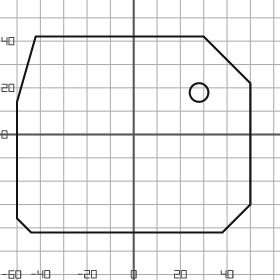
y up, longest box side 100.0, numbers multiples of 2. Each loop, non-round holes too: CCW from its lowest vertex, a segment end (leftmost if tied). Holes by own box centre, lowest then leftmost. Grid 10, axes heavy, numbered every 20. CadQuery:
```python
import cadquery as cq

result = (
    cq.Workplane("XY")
    .moveTo(-44.0, -42.0)
    .lineTo(38.0, -42.0)
    .lineTo(50.0, -30.0)
    .lineTo(50.0, 22.0)
    .lineTo(30.0, 42.0)
    .lineTo(-42.0, 42.0)
    .lineTo(-50.0, 14.0)
    .lineTo(-50.0, -36.0)
    .close()
    .moveTo(28.0, 18.0)
    .circle(4.0)
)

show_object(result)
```